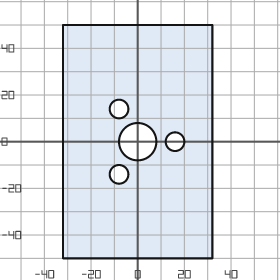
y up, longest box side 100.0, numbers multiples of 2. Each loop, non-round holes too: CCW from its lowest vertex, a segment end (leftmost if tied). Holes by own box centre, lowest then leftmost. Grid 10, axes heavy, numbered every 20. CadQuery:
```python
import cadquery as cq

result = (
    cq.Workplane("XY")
    .moveTo(-32.0, -50.0)
    .lineTo(32.0, -50.0)
    .lineTo(32.0, 50.0)
    .lineTo(-32.0, 50.0)
    .close()
    .moveTo(-8.0, -14.0)
    .circle(4.0)
    .moveTo(0.0, 0.0)
    .circle(8.0)
    .moveTo(16.0, 0.0)
    .circle(4.0)
    .moveTo(-8.0, 14.0)
    .circle(4.0)
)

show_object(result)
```